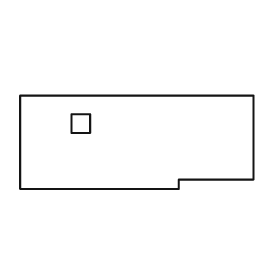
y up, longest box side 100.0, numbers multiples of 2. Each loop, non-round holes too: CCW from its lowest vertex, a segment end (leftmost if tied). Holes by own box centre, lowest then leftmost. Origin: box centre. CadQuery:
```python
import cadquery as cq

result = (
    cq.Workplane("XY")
    .moveTo(-50.0, -20.0)
    .lineTo(18.0, -20.0)
    .lineTo(18.0, -16.0)
    .lineTo(50.0, -16.0)
    .lineTo(50.0, 20.0)
    .lineTo(-50.0, 20.0)
    .close()
    .moveTo(-28.0, 4.0)
    .lineTo(-20.0, 4.0)
    .lineTo(-20.0, 12.0)
    .lineTo(-28.0, 12.0)
    .close()
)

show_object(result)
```